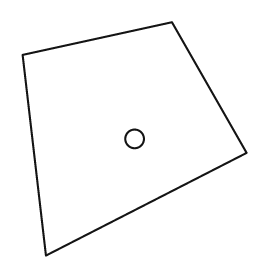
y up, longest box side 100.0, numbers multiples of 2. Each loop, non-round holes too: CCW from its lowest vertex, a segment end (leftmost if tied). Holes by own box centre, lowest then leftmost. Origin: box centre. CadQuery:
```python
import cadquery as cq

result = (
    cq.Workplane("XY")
    .moveTo(-38.0, -50.0)
    .lineTo(48.0, -6.0)
    .lineTo(16.0, 50.0)
    .lineTo(-48.0, 36.0)
    .close()
    .moveTo(0.0, 0.0)
    .circle(4.0)
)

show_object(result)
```